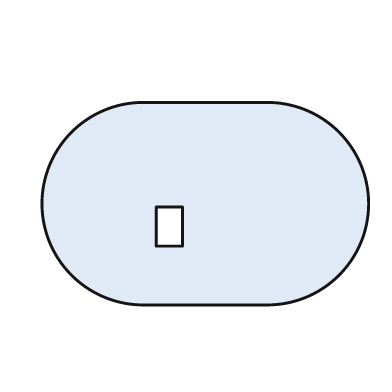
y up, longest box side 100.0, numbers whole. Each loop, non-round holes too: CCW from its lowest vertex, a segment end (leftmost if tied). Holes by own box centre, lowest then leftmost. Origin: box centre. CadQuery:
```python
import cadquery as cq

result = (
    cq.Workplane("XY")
    .moveTo(-19.0, -31.0)
    .lineTo(19.0, -31.0)
    .threePointArc((50.0, 0.0), (19.0, 31.0))
    .lineTo(-19.0, 31.0)
    .threePointArc((-50.0, 0.0), (-19.0, -31.0))
    .close()
    .moveTo(-15.0, -13.0)
    .lineTo(-7.0, -13.0)
    .lineTo(-7.0, -1.0)
    .lineTo(-15.0, -1.0)
    .close()
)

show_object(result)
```